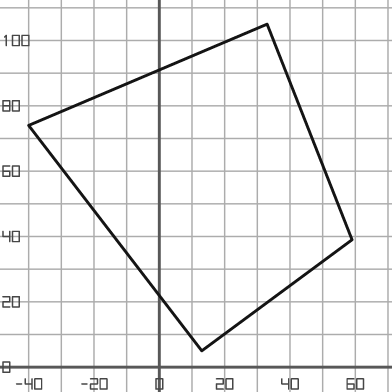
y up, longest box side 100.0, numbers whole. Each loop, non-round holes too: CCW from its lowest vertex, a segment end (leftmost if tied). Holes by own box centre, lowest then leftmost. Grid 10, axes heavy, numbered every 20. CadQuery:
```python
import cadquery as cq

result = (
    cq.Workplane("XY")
    .moveTo(13.0, 5.0)
    .lineTo(59.0, 39.0)
    .lineTo(33.0, 105.0)
    .lineTo(-40.0, 74.0)
    .close()
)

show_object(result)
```